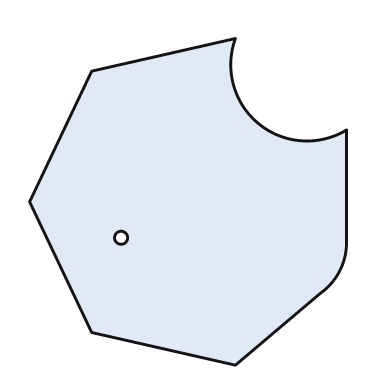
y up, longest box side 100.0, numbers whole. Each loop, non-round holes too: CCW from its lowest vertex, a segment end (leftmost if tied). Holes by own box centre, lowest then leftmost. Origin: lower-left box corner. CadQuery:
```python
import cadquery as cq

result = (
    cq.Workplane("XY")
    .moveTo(63.0, 0.0)
    .lineTo(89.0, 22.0)
    .threePointArc((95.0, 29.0), (97.0, 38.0))
    .lineTo(97.0, 72.0)
    .threePointArc((70.0, 74.0), (63.0, 100.0))
    .lineTo(19.0, 90.0)
    .lineTo(0.0, 50.0)
    .lineTo(19.0, 10.0)
    .close()
    .moveTo(28.0, 39.0)
    .circle(2.0)
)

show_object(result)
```